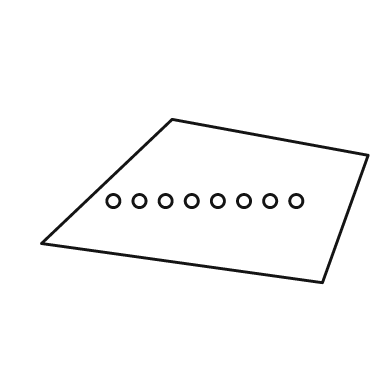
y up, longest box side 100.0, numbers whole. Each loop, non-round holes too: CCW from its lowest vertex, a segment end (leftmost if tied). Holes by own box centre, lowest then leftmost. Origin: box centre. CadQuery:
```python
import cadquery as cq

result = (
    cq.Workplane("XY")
    .moveTo(36.0, -25.0)
    .lineTo(50.0, 14.0)
    .lineTo(-10.0, 25.0)
    .lineTo(-50.0, -13.0)
    .close()
    .moveTo(-28.0, 0.0)
    .circle(2.0)
    .moveTo(-20.0, 0.0)
    .circle(2.0)
    .moveTo(-12.0, 0.0)
    .circle(2.0)
    .moveTo(-4.0, 0.0)
    .circle(2.0)
    .moveTo(4.0, 0.0)
    .circle(2.0)
    .moveTo(12.0, 0.0)
    .circle(2.0)
    .moveTo(20.0, 0.0)
    .circle(2.0)
    .moveTo(28.0, 0.0)
    .circle(2.0)
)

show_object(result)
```